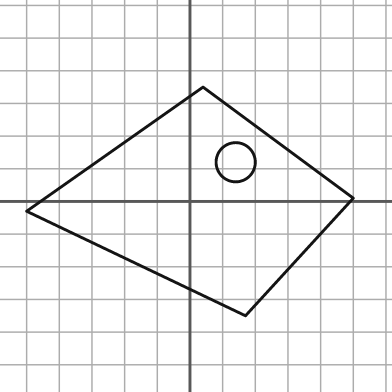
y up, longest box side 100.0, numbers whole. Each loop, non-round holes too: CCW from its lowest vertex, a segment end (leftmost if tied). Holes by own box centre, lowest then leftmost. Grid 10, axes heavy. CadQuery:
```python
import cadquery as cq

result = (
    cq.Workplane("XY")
    .moveTo(17.0, -35.0)
    .lineTo(50.0, 1.0)
    .lineTo(4.0, 35.0)
    .lineTo(-50.0, -3.0)
    .close()
    .moveTo(14.0, 12.0)
    .circle(6.0)
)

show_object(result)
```